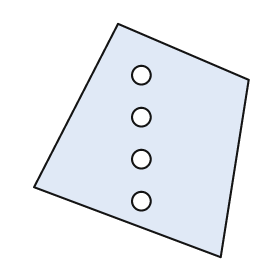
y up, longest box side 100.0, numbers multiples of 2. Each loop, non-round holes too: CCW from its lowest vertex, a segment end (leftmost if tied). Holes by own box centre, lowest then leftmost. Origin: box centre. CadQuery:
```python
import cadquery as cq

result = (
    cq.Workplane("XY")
    .moveTo(34.0, -50.0)
    .lineTo(46.0, 26.0)
    .lineTo(-10.0, 50.0)
    .lineTo(-46.0, -20.0)
    .close()
    .moveTo(0.0, -26.0)
    .circle(4.0)
    .moveTo(0.0, -8.0)
    .circle(4.0)
    .moveTo(0.0, 10.0)
    .circle(4.0)
    .moveTo(0.0, 28.0)
    .circle(4.0)
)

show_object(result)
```